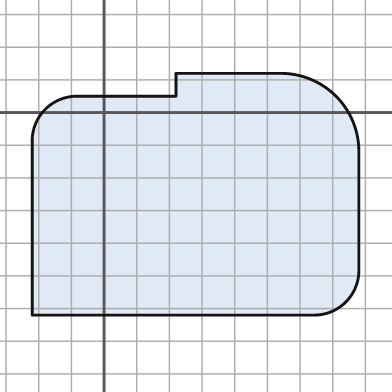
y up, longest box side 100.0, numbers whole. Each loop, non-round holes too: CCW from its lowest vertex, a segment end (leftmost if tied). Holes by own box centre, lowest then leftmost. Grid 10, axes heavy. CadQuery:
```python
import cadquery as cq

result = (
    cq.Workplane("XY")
    .moveTo(-22.0, -62.0)
    .lineTo(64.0, -62.0)
    .threePointArc((74.0, -58.0), (78.0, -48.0))
    .lineTo(78.0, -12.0)
    .threePointArc((71.0, 5.0), (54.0, 12.0))
    .lineTo(22.0, 12.0)
    .lineTo(22.0, 5.0)
    .lineTo(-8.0, 5.0)
    .threePointArc((-18.0, 1.0), (-22.0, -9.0))
    .close()
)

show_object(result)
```